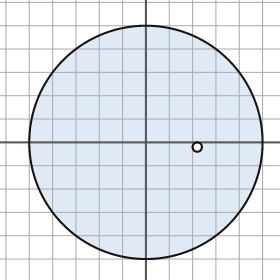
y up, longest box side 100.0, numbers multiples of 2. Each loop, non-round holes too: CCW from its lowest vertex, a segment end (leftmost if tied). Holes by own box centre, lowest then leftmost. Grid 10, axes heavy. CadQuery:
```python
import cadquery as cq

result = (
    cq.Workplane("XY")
    .moveTo(0.0, 0.0)
    .circle(50.0)
    .moveTo(22.0, -2.0)
    .circle(2.0)
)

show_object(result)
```